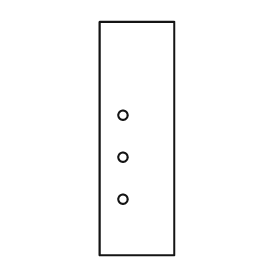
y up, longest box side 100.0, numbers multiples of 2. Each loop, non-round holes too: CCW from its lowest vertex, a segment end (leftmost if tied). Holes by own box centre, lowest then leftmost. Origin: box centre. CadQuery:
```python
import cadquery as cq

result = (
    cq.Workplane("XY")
    .moveTo(-16.0, -50.0)
    .lineTo(16.0, -50.0)
    .lineTo(16.0, 50.0)
    .lineTo(-16.0, 50.0)
    .close()
    .moveTo(-6.0, -26.0)
    .circle(2.0)
    .moveTo(-6.0, -8.0)
    .circle(2.0)
    .moveTo(-6.0, 10.0)
    .circle(2.0)
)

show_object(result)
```